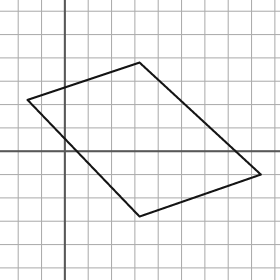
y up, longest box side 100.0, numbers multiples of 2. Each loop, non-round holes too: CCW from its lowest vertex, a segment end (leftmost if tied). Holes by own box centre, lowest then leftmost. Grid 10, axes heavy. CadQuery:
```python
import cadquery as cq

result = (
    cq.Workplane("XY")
    .moveTo(32.0, -28.0)
    .lineTo(84.0, -10.0)
    .lineTo(32.0, 38.0)
    .lineTo(-16.0, 22.0)
    .close()
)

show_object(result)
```